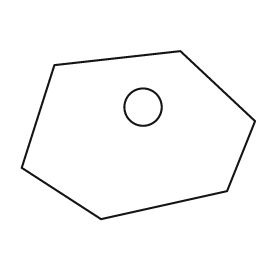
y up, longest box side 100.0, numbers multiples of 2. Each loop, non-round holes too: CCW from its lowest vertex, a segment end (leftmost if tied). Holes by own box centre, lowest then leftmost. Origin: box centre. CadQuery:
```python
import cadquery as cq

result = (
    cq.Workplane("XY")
    .moveTo(-16.0, -36.0)
    .lineTo(38.0, -24.0)
    .lineTo(50.0, 6.0)
    .lineTo(18.0, 36.0)
    .lineTo(-36.0, 30.0)
    .lineTo(-50.0, -14.0)
    .close()
    .moveTo(2.0, 12.0)
    .circle(8.0)
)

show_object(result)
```